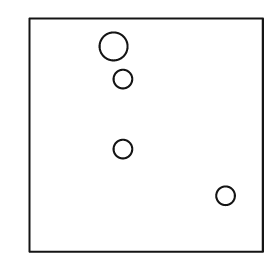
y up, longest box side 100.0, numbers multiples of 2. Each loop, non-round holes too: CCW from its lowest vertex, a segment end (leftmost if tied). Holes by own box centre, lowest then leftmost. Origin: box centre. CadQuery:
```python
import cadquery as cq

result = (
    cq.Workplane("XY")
    .moveTo(-50.0, -50.0)
    .lineTo(50.0, -50.0)
    .lineTo(50.0, 50.0)
    .lineTo(-50.0, 50.0)
    .close()
    .moveTo(34.0, -26.0)
    .circle(4.0)
    .moveTo(-10.0, -6.0)
    .circle(4.0)
    .moveTo(-10.0, 24.0)
    .circle(4.0)
    .moveTo(-14.0, 38.0)
    .circle(6.0)
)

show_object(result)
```